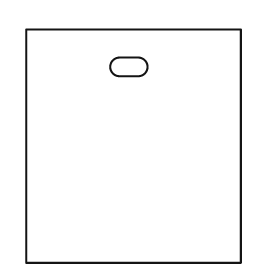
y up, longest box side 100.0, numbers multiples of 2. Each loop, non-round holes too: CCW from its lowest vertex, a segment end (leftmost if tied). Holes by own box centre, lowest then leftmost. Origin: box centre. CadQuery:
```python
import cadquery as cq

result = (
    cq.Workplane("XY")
    .moveTo(-46.0, -50.0)
    .lineTo(46.0, -50.0)
    .lineTo(46.0, 50.0)
    .lineTo(-46.0, 50.0)
    .close()
    .moveTo(-6.0, 30.0)
    .lineTo(2.0, 30.0)
    .threePointArc((6.0, 34.0), (2.0, 38.0))
    .lineTo(-6.0, 38.0)
    .threePointArc((-10.0, 34.0), (-6.0, 30.0))
    .close()
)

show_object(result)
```